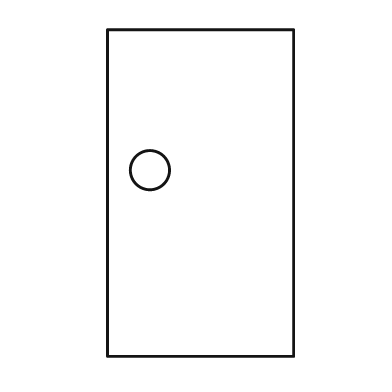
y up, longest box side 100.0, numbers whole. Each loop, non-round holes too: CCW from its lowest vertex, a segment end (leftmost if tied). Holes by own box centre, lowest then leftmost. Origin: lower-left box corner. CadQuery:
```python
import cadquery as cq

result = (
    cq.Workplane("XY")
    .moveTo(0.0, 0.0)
    .lineTo(57.0, 0.0)
    .lineTo(57.0, 100.0)
    .lineTo(0.0, 100.0)
    .close()
    .moveTo(13.0, 57.0)
    .circle(6.0)
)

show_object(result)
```